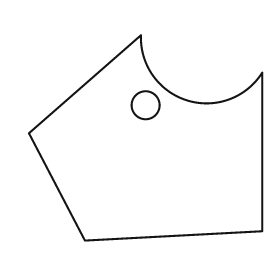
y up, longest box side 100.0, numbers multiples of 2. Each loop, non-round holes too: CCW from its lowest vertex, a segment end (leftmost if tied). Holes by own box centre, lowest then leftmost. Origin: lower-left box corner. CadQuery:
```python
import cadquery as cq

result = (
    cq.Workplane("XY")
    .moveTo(24.0, 0.0)
    .lineTo(100.0, 4.0)
    .lineTo(100.0, 72.0)
    .threePointArc((68.0, 60.0), (48.0, 88.0))
    .lineTo(0.0, 46.0)
    .close()
    .moveTo(50.0, 58.0)
    .circle(6.0)
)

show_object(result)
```